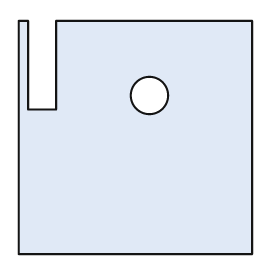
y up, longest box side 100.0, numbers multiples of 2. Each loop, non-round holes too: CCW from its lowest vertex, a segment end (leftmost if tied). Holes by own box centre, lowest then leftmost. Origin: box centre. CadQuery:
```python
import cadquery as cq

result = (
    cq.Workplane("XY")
    .moveTo(-50.0, -50.0)
    .lineTo(50.0, -50.0)
    .lineTo(50.0, 50.0)
    .lineTo(-34.0, 50.0)
    .lineTo(-34.0, 12.0)
    .lineTo(-46.0, 12.0)
    .lineTo(-46.0, 50.0)
    .lineTo(-50.0, 50.0)
    .close()
    .moveTo(6.0, 18.0)
    .circle(8.0)
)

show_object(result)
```